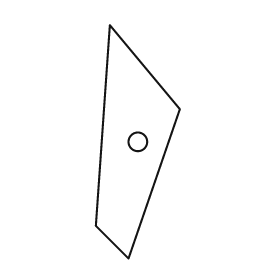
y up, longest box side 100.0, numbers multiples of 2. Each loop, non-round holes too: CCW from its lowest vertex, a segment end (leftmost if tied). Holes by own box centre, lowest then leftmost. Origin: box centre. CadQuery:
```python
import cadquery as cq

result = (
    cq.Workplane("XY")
    .moveTo(-4.0, -50.0)
    .lineTo(18.0, 14.0)
    .lineTo(-12.0, 50.0)
    .lineTo(-18.0, -36.0)
    .close()
    .moveTo(0.0, 0.0)
    .circle(4.0)
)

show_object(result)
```